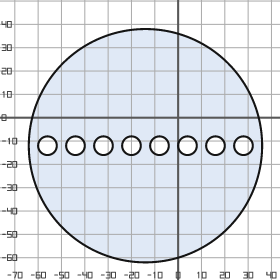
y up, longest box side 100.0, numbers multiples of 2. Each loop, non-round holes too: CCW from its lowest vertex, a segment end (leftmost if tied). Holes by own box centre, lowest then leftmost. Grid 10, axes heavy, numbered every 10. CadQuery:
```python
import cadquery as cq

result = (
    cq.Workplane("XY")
    .moveTo(-14.0, -12.0)
    .circle(50.0)
    .moveTo(-56.0, -12.0)
    .circle(4.0)
    .moveTo(-44.0, -12.0)
    .circle(4.0)
    .moveTo(-32.0, -12.0)
    .circle(4.0)
    .moveTo(-20.0, -12.0)
    .circle(4.0)
    .moveTo(-8.0, -12.0)
    .circle(4.0)
    .moveTo(4.0, -12.0)
    .circle(4.0)
    .moveTo(16.0, -12.0)
    .circle(4.0)
    .moveTo(28.0, -12.0)
    .circle(4.0)
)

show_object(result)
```